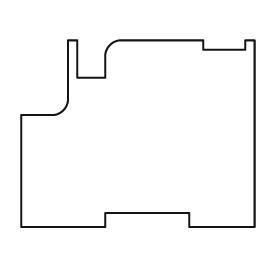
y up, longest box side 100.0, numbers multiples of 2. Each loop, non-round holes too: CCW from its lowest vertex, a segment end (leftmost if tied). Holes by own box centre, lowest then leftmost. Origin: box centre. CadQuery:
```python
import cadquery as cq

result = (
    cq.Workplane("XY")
    .moveTo(-50.0, -40.0)
    .lineTo(-14.0, -40.0)
    .lineTo(-14.0, -34.0)
    .lineTo(22.0, -34.0)
    .lineTo(22.0, -40.0)
    .lineTo(50.0, -40.0)
    .lineTo(50.0, 40.0)
    .lineTo(46.0, 40.0)
    .lineTo(46.0, 36.0)
    .lineTo(28.0, 36.0)
    .lineTo(28.0, 40.0)
    .lineTo(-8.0, 40.0)
    .threePointArc((-12.0, 38.0), (-14.0, 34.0))
    .lineTo(-14.0, 24.0)
    .lineTo(-26.0, 24.0)
    .lineTo(-26.0, 40.0)
    .lineTo(-30.0, 40.0)
    .lineTo(-30.0, 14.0)
    .threePointArc((-32.0, 10.0), (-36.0, 8.0))
    .lineTo(-50.0, 8.0)
    .close()
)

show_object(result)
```